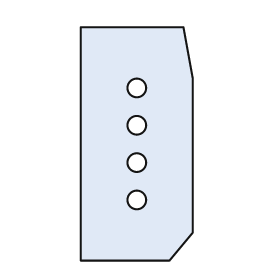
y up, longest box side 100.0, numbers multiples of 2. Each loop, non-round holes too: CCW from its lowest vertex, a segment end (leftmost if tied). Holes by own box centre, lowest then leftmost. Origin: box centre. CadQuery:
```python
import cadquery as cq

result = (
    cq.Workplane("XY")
    .moveTo(-24.0, -50.0)
    .lineTo(14.0, -50.0)
    .lineTo(24.0, -38.0)
    .lineTo(24.0, 28.0)
    .lineTo(20.0, 50.0)
    .lineTo(-24.0, 50.0)
    .close()
    .moveTo(0.0, -24.0)
    .circle(4.0)
    .moveTo(0.0, -8.0)
    .circle(4.0)
    .moveTo(0.0, 8.0)
    .circle(4.0)
    .moveTo(0.0, 24.0)
    .circle(4.0)
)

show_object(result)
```